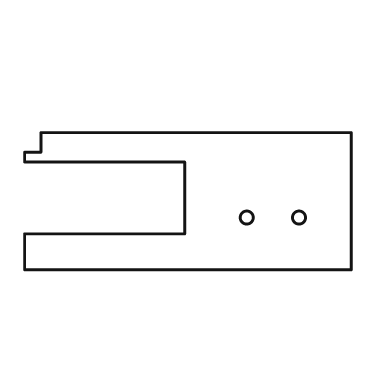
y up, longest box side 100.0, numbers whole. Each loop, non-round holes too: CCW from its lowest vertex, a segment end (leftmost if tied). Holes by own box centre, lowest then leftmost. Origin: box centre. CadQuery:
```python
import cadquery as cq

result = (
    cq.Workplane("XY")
    .moveTo(-50.0, -21.0)
    .lineTo(50.0, -21.0)
    .lineTo(50.0, 21.0)
    .lineTo(-45.0, 21.0)
    .lineTo(-45.0, 15.0)
    .lineTo(-50.0, 15.0)
    .lineTo(-50.0, 12.0)
    .lineTo(-1.0, 12.0)
    .lineTo(-1.0, -10.0)
    .lineTo(-50.0, -10.0)
    .close()
    .moveTo(18.0, -5.0)
    .circle(2.0)
    .moveTo(34.0, -5.0)
    .circle(2.0)
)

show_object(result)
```